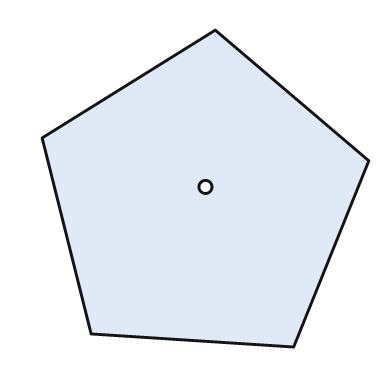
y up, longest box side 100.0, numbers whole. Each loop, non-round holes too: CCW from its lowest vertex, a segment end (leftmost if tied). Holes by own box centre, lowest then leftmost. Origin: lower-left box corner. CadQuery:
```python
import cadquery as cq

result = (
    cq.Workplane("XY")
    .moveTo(77.0, 0.0)
    .lineTo(100.0, 57.0)
    .lineTo(53.0, 97.0)
    .lineTo(0.0, 64.0)
    .lineTo(15.0, 4.0)
    .close()
    .moveTo(50.0, 49.0)
    .circle(2.0)
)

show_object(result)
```